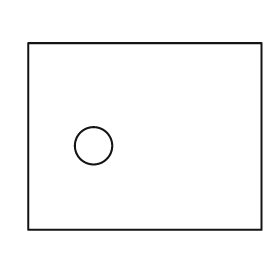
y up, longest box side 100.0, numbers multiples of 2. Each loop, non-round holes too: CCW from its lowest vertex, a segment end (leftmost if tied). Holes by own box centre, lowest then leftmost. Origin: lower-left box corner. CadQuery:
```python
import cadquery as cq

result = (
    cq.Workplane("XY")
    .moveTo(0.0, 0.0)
    .lineTo(100.0, 0.0)
    .lineTo(100.0, 80.0)
    .lineTo(0.0, 80.0)
    .close()
    .moveTo(28.0, 36.0)
    .circle(8.0)
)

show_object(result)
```